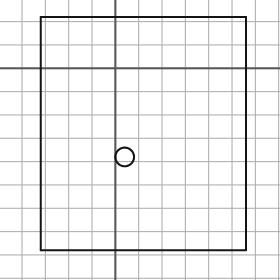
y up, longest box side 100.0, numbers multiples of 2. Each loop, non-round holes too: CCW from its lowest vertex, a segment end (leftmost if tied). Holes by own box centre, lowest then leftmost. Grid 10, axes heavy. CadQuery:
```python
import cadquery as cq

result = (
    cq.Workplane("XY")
    .moveTo(-32.0, -78.0)
    .lineTo(56.0, -78.0)
    .lineTo(56.0, 22.0)
    .lineTo(-32.0, 22.0)
    .close()
    .moveTo(4.0, -38.0)
    .circle(4.0)
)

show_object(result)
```